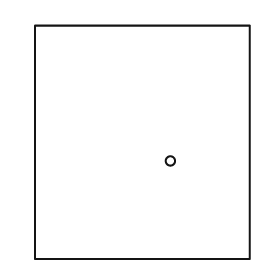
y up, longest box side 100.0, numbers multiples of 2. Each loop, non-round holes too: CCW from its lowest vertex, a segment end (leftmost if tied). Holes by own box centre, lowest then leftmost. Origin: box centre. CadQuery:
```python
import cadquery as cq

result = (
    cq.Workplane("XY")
    .moveTo(-46.0, -50.0)
    .lineTo(46.0, -50.0)
    .lineTo(46.0, 50.0)
    .lineTo(-46.0, 50.0)
    .close()
    .moveTo(12.0, -8.0)
    .circle(2.0)
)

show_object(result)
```